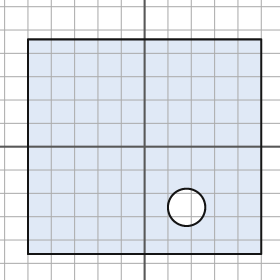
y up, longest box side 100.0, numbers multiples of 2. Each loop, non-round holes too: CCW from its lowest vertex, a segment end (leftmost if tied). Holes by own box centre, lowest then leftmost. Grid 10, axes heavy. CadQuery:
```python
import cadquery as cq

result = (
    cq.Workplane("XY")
    .moveTo(-50.0, -46.0)
    .lineTo(50.0, -46.0)
    .lineTo(50.0, 46.0)
    .lineTo(-50.0, 46.0)
    .close()
    .moveTo(18.0, -26.0)
    .circle(8.0)
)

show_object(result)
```